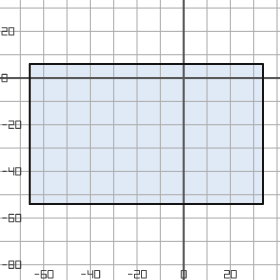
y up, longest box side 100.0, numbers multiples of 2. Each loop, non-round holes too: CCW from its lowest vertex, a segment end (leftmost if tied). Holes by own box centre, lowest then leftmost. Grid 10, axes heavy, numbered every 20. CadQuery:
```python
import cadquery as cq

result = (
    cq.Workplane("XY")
    .moveTo(-66.0, -54.0)
    .lineTo(34.0, -54.0)
    .lineTo(34.0, 6.0)
    .lineTo(-66.0, 6.0)
    .close()
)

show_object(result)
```